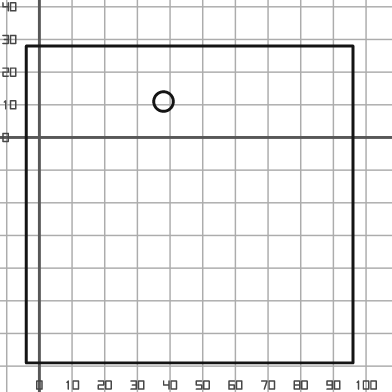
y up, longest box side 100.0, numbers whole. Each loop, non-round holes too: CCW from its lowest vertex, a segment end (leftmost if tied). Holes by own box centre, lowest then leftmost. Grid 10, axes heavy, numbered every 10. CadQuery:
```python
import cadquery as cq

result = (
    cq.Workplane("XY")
    .moveTo(-4.0, -69.0)
    .lineTo(96.0, -69.0)
    .lineTo(96.0, 28.0)
    .lineTo(-4.0, 28.0)
    .close()
    .moveTo(38.0, 11.0)
    .circle(3.0)
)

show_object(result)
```